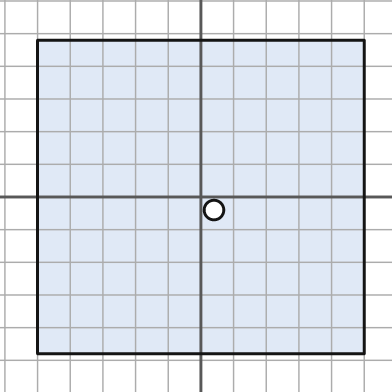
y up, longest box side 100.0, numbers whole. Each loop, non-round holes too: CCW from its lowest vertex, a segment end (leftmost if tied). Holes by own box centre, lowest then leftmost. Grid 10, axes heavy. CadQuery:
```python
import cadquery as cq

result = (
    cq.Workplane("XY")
    .moveTo(-50.0, -48.0)
    .lineTo(50.0, -48.0)
    .lineTo(50.0, 48.0)
    .lineTo(-50.0, 48.0)
    .close()
    .moveTo(4.0, -4.0)
    .circle(3.0)
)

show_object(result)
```